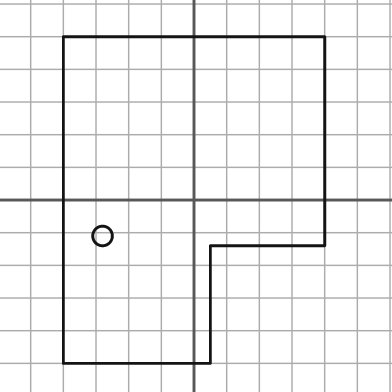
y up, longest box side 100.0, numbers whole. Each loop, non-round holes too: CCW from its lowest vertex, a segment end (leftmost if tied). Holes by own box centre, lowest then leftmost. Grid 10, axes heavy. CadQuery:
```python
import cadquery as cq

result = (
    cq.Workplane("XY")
    .moveTo(-40.0, -50.0)
    .lineTo(5.0, -50.0)
    .lineTo(5.0, -14.0)
    .lineTo(40.0, -14.0)
    .lineTo(40.0, 50.0)
    .lineTo(-40.0, 50.0)
    .close()
    .moveTo(-28.0, -11.0)
    .circle(3.0)
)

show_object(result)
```